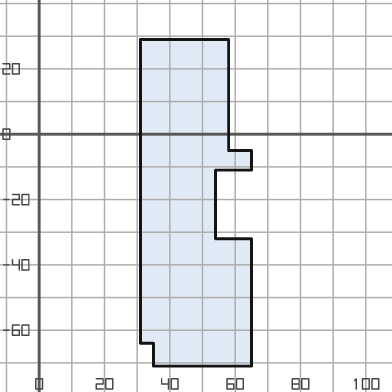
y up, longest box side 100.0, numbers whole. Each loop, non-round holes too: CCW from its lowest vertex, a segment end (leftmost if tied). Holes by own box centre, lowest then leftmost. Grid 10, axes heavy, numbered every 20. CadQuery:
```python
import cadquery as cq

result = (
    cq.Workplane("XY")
    .moveTo(35.0, -71.0)
    .lineTo(65.0, -71.0)
    .lineTo(65.0, -32.0)
    .lineTo(54.0, -32.0)
    .lineTo(54.0, -11.0)
    .lineTo(65.0, -11.0)
    .lineTo(65.0, -5.0)
    .lineTo(58.0, -5.0)
    .lineTo(58.0, 29.0)
    .lineTo(31.0, 29.0)
    .lineTo(31.0, -64.0)
    .lineTo(35.0, -64.0)
    .close()
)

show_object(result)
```